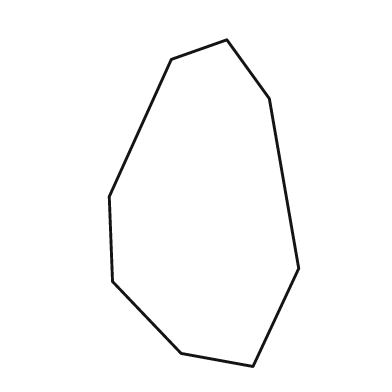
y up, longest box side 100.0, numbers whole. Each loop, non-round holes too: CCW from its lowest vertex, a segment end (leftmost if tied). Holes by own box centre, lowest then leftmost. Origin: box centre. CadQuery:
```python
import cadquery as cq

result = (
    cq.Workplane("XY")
    .moveTo(15.0, -50.0)
    .lineTo(29.0, -20.0)
    .lineTo(20.0, 32.0)
    .lineTo(7.0, 50.0)
    .lineTo(-10.0, 44.0)
    .lineTo(-29.0, 2.0)
    .lineTo(-28.0, -24.0)
    .lineTo(-7.0, -46.0)
    .close()
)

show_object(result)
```